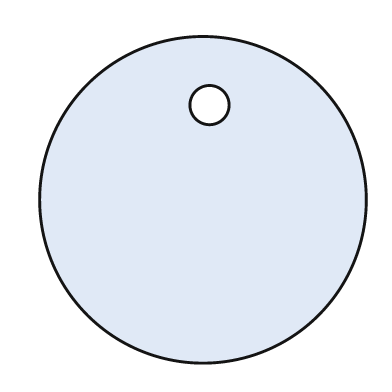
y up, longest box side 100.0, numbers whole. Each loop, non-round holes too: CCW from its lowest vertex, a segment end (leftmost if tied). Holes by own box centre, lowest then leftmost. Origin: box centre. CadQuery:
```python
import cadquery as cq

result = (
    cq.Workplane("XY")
    .moveTo(0.0, 0.0)
    .circle(50.0)
    .moveTo(2.0, 29.0)
    .circle(6.0)
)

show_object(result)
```